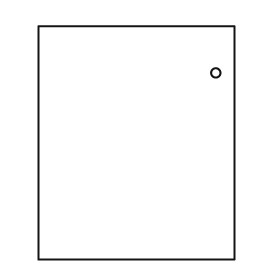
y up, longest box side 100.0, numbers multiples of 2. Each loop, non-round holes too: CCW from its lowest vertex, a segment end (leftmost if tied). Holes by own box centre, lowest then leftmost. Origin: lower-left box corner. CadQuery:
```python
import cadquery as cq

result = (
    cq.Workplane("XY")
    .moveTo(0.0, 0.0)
    .lineTo(84.0, 0.0)
    .lineTo(84.0, 100.0)
    .lineTo(0.0, 100.0)
    .close()
    .moveTo(76.0, 80.0)
    .circle(2.0)
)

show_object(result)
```